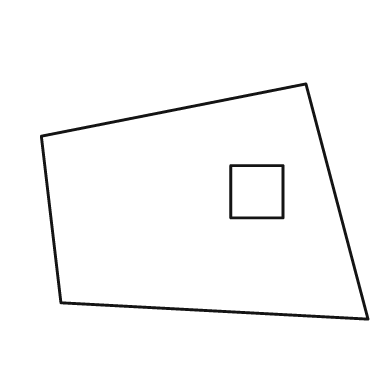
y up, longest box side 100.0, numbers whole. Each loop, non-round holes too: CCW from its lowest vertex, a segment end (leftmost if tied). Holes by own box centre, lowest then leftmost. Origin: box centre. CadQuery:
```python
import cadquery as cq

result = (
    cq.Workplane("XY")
    .moveTo(50.0, -36.0)
    .lineTo(31.0, 36.0)
    .lineTo(-50.0, 20.0)
    .lineTo(-44.0, -31.0)
    .close()
    .moveTo(8.0, -5.0)
    .lineTo(24.0, -5.0)
    .lineTo(24.0, 11.0)
    .lineTo(8.0, 11.0)
    .close()
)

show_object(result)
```